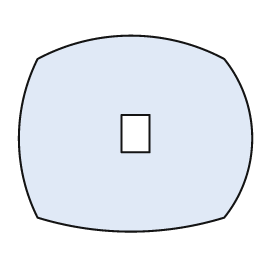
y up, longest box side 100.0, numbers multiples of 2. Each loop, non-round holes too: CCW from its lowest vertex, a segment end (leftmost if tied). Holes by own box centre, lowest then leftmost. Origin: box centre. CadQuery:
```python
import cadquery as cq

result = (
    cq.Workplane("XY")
    .moveTo(-42.0, -36.0)
    .threePointArc((-2.0, -42.0), (38.0, -36.0))
    .threePointArc((50.0, -2.0), (38.0, 32.0))
    .threePointArc((-2.0, 42.0), (-42.0, 32.0))
    .threePointArc((-50.0, -2.0), (-42.0, -36.0))
    .close()
    .moveTo(-6.0, -8.0)
    .lineTo(6.0, -8.0)
    .lineTo(6.0, 8.0)
    .lineTo(-6.0, 8.0)
    .close()
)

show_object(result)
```